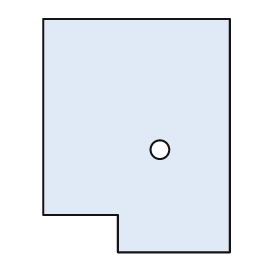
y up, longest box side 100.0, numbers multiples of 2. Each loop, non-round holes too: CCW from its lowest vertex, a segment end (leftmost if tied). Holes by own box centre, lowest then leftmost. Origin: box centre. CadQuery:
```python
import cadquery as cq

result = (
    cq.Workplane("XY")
    .moveTo(-8.0, -50.0)
    .lineTo(40.0, -50.0)
    .lineTo(40.0, 50.0)
    .lineTo(-40.0, 50.0)
    .lineTo(-40.0, -34.0)
    .lineTo(-8.0, -34.0)
    .close()
    .moveTo(10.0, -6.0)
    .circle(4.0)
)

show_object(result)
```